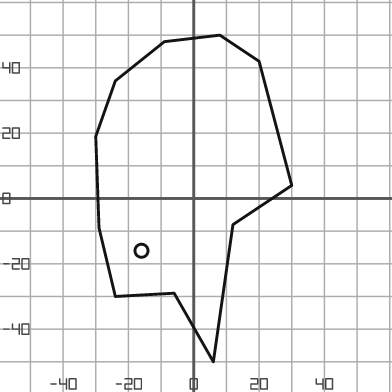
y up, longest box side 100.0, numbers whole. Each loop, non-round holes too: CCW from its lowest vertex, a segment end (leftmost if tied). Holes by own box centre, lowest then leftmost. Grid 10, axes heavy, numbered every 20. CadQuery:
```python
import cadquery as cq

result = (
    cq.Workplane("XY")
    .moveTo(6.0, -50.0)
    .lineTo(12.0, -8.0)
    .lineTo(30.0, 4.0)
    .lineTo(20.0, 42.0)
    .lineTo(8.0, 50.0)
    .lineTo(-9.0, 48.0)
    .lineTo(-24.0, 36.0)
    .lineTo(-30.0, 19.0)
    .lineTo(-29.0, -9.0)
    .lineTo(-24.0, -30.0)
    .lineTo(-6.0, -29.0)
    .close()
    .moveTo(-16.0, -16.0)
    .circle(2.0)
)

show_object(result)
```